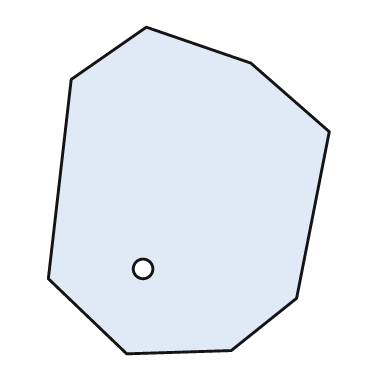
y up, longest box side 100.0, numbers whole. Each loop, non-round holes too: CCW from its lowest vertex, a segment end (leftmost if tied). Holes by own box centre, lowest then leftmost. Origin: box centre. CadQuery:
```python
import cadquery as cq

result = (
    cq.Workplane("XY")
    .moveTo(-19.0, -50.0)
    .lineTo(13.0, -49.0)
    .lineTo(33.0, -33.0)
    .lineTo(43.0, 18.0)
    .lineTo(19.0, 39.0)
    .lineTo(-13.0, 50.0)
    .lineTo(-36.0, 34.0)
    .lineTo(-43.0, -27.0)
    .close()
    .moveTo(-14.0, -24.0)
    .circle(3.0)
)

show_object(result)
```